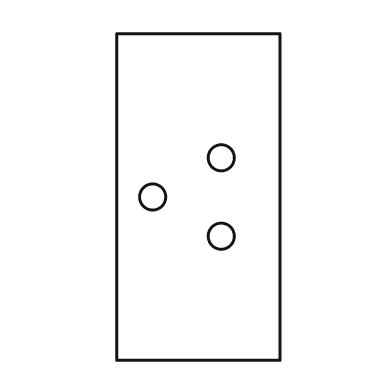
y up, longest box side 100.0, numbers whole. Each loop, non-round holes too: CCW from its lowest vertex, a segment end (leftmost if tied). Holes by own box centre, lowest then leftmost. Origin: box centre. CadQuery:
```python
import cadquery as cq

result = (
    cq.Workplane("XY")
    .moveTo(-25.0, -50.0)
    .lineTo(25.0, -50.0)
    .lineTo(25.0, 50.0)
    .lineTo(-25.0, 50.0)
    .close()
    .moveTo(7.0, -12.0)
    .circle(4.0)
    .moveTo(-14.0, 0.0)
    .circle(4.0)
    .moveTo(7.0, 12.0)
    .circle(4.0)
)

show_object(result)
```